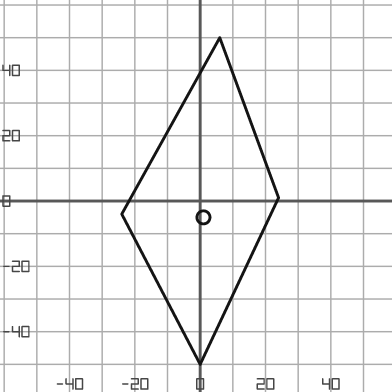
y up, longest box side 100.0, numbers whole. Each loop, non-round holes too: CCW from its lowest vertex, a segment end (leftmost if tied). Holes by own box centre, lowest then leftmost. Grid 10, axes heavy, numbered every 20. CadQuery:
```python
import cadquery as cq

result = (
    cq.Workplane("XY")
    .moveTo(0.0, -50.0)
    .lineTo(24.0, 1.0)
    .lineTo(6.0, 50.0)
    .lineTo(-24.0, -4.0)
    .close()
    .moveTo(1.0, -5.0)
    .circle(2.0)
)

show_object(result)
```